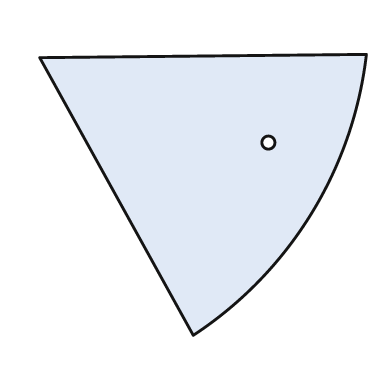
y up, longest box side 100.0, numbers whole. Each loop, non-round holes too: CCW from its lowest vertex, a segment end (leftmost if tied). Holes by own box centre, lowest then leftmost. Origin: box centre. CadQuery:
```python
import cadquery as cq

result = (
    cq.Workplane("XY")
    .moveTo(-3.0, -43.0)
    .threePointArc((33.0, -6.0), (50.0, 43.0))
    .lineTo(-50.0, 42.0)
    .close()
    .moveTo(20.0, 16.0)
    .circle(2.0)
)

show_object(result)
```